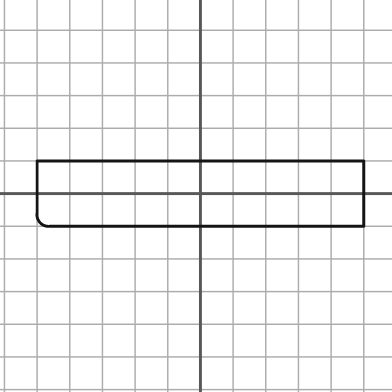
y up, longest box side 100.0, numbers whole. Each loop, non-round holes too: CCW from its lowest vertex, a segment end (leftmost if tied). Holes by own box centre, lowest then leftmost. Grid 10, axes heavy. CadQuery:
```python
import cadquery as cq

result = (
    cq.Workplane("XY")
    .moveTo(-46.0, -10.0)
    .lineTo(50.0, -10.0)
    .lineTo(50.0, 10.0)
    .lineTo(-50.0, 10.0)
    .lineTo(-50.0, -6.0)
    .threePointArc((-49.0, -9.0), (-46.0, -10.0))
    .close()
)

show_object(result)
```